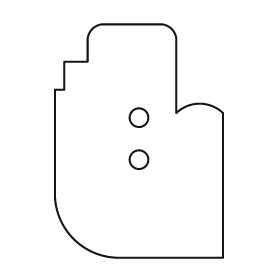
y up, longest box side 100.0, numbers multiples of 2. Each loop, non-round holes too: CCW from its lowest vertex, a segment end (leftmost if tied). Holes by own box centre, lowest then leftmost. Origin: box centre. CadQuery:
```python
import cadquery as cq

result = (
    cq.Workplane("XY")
    .moveTo(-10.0, -50.0)
    .lineTo(36.0, -50.0)
    .lineTo(36.0, 12.0)
    .threePointArc((26.0, 16.0), (16.0, 12.0))
    .lineTo(16.0, 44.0)
    .threePointArc((14.0, 48.0), (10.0, 50.0))
    .lineTo(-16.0, 50.0)
    .threePointArc((-20.0, 48.0), (-22.0, 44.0))
    .lineTo(-22.0, 34.0)
    .lineTo(-32.0, 34.0)
    .lineTo(-32.0, 22.0)
    .lineTo(-36.0, 22.0)
    .lineTo(-36.0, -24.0)
    .threePointArc((-28.0, -42.0), (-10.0, -50.0))
    .close()
    .moveTo(0.0, -8.0)
    .circle(4.0)
    .moveTo(0.0, 10.0)
    .circle(4.0)
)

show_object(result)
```